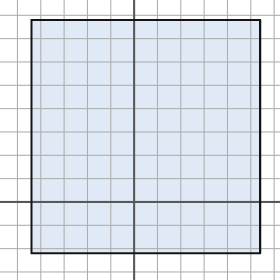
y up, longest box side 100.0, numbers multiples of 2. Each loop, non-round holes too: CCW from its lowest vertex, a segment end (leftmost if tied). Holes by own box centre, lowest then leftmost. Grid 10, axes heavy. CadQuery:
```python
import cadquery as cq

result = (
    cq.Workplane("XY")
    .moveTo(-44.0, -22.0)
    .lineTo(54.0, -22.0)
    .lineTo(54.0, 78.0)
    .lineTo(-44.0, 78.0)
    .close()
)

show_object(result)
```